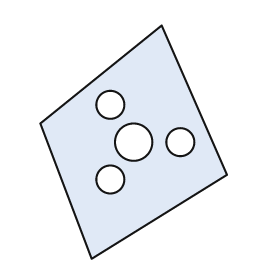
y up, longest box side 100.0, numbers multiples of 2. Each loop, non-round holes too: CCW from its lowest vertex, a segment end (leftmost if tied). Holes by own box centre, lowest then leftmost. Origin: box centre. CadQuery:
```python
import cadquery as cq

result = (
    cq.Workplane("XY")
    .moveTo(-18.0, -50.0)
    .lineTo(40.0, -14.0)
    .lineTo(12.0, 50.0)
    .lineTo(-40.0, 8.0)
    .close()
    .moveTo(-10.0, -16.0)
    .circle(6.0)
    .moveTo(0.0, 0.0)
    .circle(8.0)
    .moveTo(20.0, 0.0)
    .circle(6.0)
    .moveTo(-10.0, 16.0)
    .circle(6.0)
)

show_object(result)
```